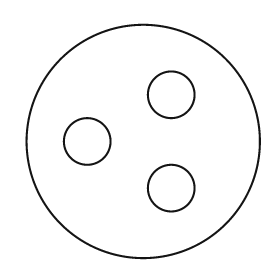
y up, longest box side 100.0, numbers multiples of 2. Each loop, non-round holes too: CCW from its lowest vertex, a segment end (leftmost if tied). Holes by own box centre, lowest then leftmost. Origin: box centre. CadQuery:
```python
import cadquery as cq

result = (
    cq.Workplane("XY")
    .moveTo(0.0, 0.0)
    .circle(50.0)
    .moveTo(12.0, -20.0)
    .circle(10.0)
    .moveTo(-24.0, 0.0)
    .circle(10.0)
    .moveTo(12.0, 20.0)
    .circle(10.0)
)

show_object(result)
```